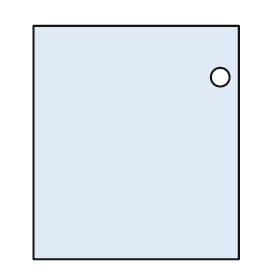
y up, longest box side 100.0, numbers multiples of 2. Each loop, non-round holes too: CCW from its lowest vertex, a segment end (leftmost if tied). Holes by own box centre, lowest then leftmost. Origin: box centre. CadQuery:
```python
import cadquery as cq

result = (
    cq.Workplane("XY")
    .moveTo(-44.0, -50.0)
    .lineTo(44.0, -50.0)
    .lineTo(44.0, 50.0)
    .lineTo(-44.0, 50.0)
    .close()
    .moveTo(36.0, 28.0)
    .circle(4.0)
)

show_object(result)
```